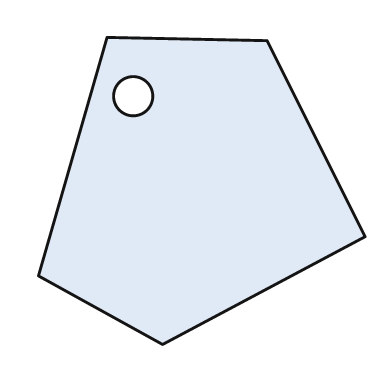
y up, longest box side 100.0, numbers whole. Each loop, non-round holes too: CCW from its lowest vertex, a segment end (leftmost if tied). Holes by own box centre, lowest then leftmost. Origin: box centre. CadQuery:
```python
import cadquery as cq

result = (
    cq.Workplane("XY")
    .moveTo(-12.0, -47.0)
    .lineTo(50.0, -14.0)
    .lineTo(20.0, 46.0)
    .lineTo(-29.0, 47.0)
    .lineTo(-50.0, -26.0)
    .close()
    .moveTo(-21.0, 29.0)
    .circle(6.0)
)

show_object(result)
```